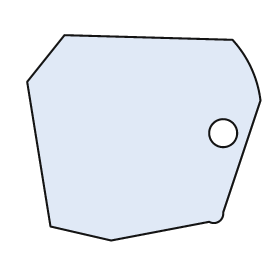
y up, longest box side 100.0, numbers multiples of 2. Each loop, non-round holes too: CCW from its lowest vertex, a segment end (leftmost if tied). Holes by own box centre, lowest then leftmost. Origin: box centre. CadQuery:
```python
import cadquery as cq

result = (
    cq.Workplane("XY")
    .moveTo(-14.0, -44.0)
    .lineTo(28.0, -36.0)
    .threePointArc((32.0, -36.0), (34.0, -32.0))
    .lineTo(50.0, 16.0)
    .threePointArc((46.0, 30.0), (38.0, 42.0))
    .lineTo(-34.0, 44.0)
    .lineTo(-50.0, 24.0)
    .lineTo(-40.0, -38.0)
    .close()
    .moveTo(34.0, 2.0)
    .circle(6.0)
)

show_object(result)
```